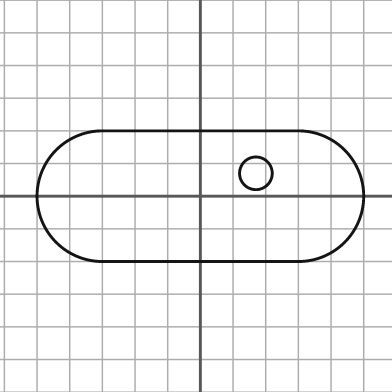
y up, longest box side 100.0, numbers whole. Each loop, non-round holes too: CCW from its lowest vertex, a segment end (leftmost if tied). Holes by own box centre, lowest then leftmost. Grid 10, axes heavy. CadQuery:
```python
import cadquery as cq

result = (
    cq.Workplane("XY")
    .moveTo(-30.0, -20.0)
    .lineTo(30.0, -20.0)
    .threePointArc((50.0, 0.0), (30.0, 20.0))
    .lineTo(-30.0, 20.0)
    .threePointArc((-50.0, 0.0), (-30.0, -20.0))
    .close()
    .moveTo(17.0, 7.0)
    .circle(5.0)
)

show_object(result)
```